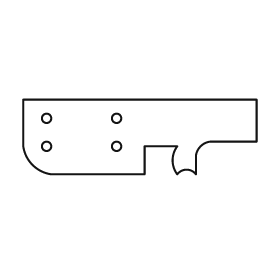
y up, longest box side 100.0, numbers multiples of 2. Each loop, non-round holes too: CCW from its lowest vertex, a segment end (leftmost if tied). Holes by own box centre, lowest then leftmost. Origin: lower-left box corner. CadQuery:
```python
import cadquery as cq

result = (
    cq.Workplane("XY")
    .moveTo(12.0, 0.0)
    .lineTo(52.0, 0.0)
    .lineTo(52.0, 12.0)
    .lineTo(66.0, 12.0)
    .threePointArc((64.0, 6.0), (66.0, 0.0))
    .threePointArc((70.0, 2.0), (74.0, 0.0))
    .lineTo(74.0, 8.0)
    .threePointArc((76.0, 12.0), (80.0, 14.0))
    .lineTo(100.0, 14.0)
    .lineTo(100.0, 32.0)
    .lineTo(0.0, 32.0)
    .lineTo(0.0, 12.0)
    .threePointArc((4.0, 4.0), (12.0, 0.0))
    .close()
    .moveTo(10.0, 12.0)
    .circle(2.0)
    .moveTo(40.0, 12.0)
    .circle(2.0)
    .moveTo(10.0, 24.0)
    .circle(2.0)
    .moveTo(40.0, 24.0)
    .circle(2.0)
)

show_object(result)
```